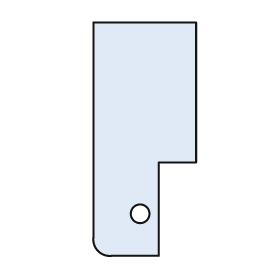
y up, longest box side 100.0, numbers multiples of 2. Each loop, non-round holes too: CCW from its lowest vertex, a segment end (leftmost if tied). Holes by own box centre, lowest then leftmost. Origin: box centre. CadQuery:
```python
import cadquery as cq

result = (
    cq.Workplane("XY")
    .moveTo(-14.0, -50.0)
    .lineTo(6.0, -50.0)
    .lineTo(6.0, -10.0)
    .lineTo(22.0, -10.0)
    .lineTo(22.0, 50.0)
    .lineTo(-22.0, 50.0)
    .lineTo(-22.0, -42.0)
    .threePointArc((-20.0, -48.0), (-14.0, -50.0))
    .close()
    .moveTo(-2.0, -32.0)
    .circle(4.0)
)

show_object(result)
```